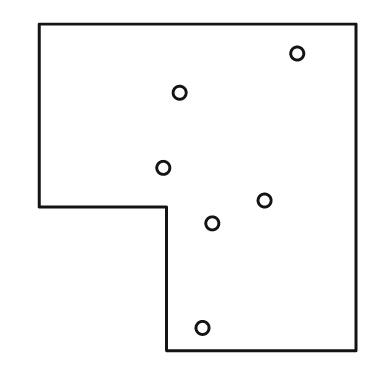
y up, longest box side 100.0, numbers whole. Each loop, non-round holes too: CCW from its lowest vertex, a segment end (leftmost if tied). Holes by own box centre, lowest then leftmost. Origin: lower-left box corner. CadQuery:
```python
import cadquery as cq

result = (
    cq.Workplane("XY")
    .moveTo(39.0, 0.0)
    .lineTo(97.0, 0.0)
    .lineTo(97.0, 100.0)
    .lineTo(0.0, 100.0)
    .lineTo(0.0, 44.0)
    .lineTo(39.0, 44.0)
    .close()
    .moveTo(50.0, 7.0)
    .circle(2.0)
    .moveTo(53.0, 39.0)
    .circle(2.0)
    .moveTo(69.0, 46.0)
    .circle(2.0)
    .moveTo(38.0, 56.0)
    .circle(2.0)
    .moveTo(43.0, 79.0)
    .circle(2.0)
    .moveTo(79.0, 91.0)
    .circle(2.0)
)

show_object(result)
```